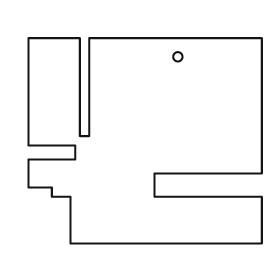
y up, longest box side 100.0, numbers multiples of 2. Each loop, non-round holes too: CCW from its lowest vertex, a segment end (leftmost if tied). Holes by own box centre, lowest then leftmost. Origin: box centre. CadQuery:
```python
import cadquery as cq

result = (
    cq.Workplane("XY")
    .moveTo(-32.0, -44.0)
    .lineTo(50.0, -44.0)
    .lineTo(50.0, -24.0)
    .lineTo(4.0, -24.0)
    .lineTo(4.0, -14.0)
    .lineTo(50.0, -14.0)
    .lineTo(50.0, 44.0)
    .lineTo(-24.0, 44.0)
    .lineTo(-24.0, 2.0)
    .lineTo(-28.0, 2.0)
    .lineTo(-28.0, 44.0)
    .lineTo(-50.0, 44.0)
    .lineTo(-50.0, -2.0)
    .lineTo(-30.0, -2.0)
    .lineTo(-30.0, -8.0)
    .lineTo(-50.0, -8.0)
    .lineTo(-50.0, -20.0)
    .lineTo(-40.0, -20.0)
    .lineTo(-40.0, -24.0)
    .lineTo(-32.0, -24.0)
    .close()
    .moveTo(14.0, 36.0)
    .circle(2.0)
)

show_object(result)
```